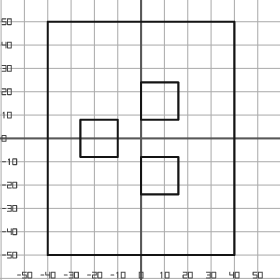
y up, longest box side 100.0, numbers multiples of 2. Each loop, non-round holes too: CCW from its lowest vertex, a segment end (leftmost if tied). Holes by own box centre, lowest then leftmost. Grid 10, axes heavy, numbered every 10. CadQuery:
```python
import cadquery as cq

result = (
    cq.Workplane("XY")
    .moveTo(-40.0, -50.0)
    .lineTo(40.0, -50.0)
    .lineTo(40.0, 50.0)
    .lineTo(-40.0, 50.0)
    .close()
    .moveTo(0.0, -24.0)
    .lineTo(16.0, -24.0)
    .lineTo(16.0, -8.0)
    .lineTo(0.0, -8.0)
    .close()
    .moveTo(-26.0, -8.0)
    .lineTo(-10.0, -8.0)
    .lineTo(-10.0, 8.0)
    .lineTo(-26.0, 8.0)
    .close()
    .moveTo(0.0, 8.0)
    .lineTo(16.0, 8.0)
    .lineTo(16.0, 24.0)
    .lineTo(0.0, 24.0)
    .close()
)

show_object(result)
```